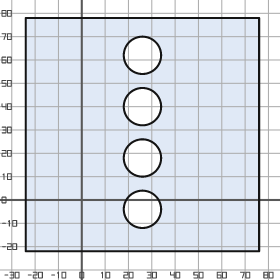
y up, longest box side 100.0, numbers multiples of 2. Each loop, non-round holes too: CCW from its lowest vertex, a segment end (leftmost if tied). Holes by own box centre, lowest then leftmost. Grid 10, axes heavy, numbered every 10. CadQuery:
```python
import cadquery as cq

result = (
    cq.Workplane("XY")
    .moveTo(-24.0, -22.0)
    .lineTo(76.0, -22.0)
    .lineTo(76.0, 78.0)
    .lineTo(-24.0, 78.0)
    .close()
    .moveTo(26.0, -4.0)
    .circle(8.0)
    .moveTo(26.0, 18.0)
    .circle(8.0)
    .moveTo(26.0, 40.0)
    .circle(8.0)
    .moveTo(26.0, 62.0)
    .circle(8.0)
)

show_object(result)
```